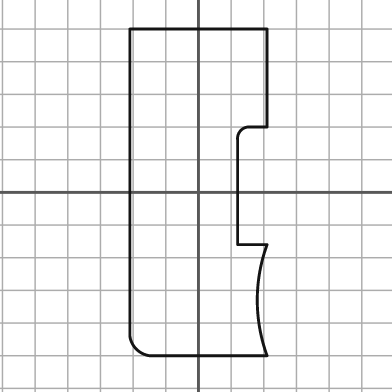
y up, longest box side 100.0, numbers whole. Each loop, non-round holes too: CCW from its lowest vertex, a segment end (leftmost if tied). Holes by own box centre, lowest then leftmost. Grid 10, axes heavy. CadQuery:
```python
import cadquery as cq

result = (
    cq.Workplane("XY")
    .moveTo(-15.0, -50.0)
    .lineTo(21.0, -50.0)
    .threePointArc((18.0, -33.0), (21.0, -16.0))
    .lineTo(12.0, -16.0)
    .lineTo(12.0, 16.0)
    .threePointArc((13.0, 19.0), (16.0, 20.0))
    .lineTo(21.0, 20.0)
    .lineTo(21.0, 50.0)
    .lineTo(-21.0, 50.0)
    .lineTo(-21.0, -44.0)
    .threePointArc((-19.0, -48.0), (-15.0, -50.0))
    .close()
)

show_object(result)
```